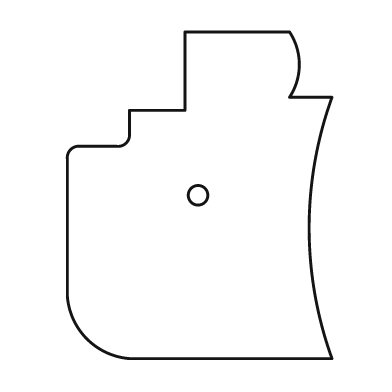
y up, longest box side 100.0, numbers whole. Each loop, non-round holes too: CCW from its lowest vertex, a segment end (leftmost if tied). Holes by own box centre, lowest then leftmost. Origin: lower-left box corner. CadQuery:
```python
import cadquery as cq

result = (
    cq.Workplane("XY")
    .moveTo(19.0, 0.0)
    .lineTo(81.0, 0.0)
    .threePointArc((74.0, 40.0), (81.0, 80.0))
    .lineTo(68.0, 80.0)
    .threePointArc((71.0, 90.0), (68.0, 100.0))
    .lineTo(36.0, 100.0)
    .lineTo(36.0, 76.0)
    .lineTo(19.0, 76.0)
    .lineTo(19.0, 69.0)
    .threePointArc((18.0, 66.0), (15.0, 65.0))
    .lineTo(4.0, 65.0)
    .threePointArc((1.0, 64.0), (0.0, 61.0))
    .lineTo(0.0, 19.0)
    .threePointArc((6.0, 6.0), (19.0, 0.0))
    .close()
    .moveTo(40.0, 50.0)
    .circle(3.0)
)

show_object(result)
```